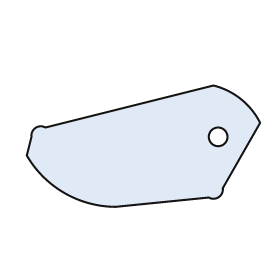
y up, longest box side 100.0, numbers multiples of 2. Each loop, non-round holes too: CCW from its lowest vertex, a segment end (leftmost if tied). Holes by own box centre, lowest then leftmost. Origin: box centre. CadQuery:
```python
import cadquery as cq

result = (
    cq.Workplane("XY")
    .moveTo(-12.0, -26.0)
    .lineTo(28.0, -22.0)
    .threePointArc((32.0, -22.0), (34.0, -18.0))
    .lineTo(50.0, 10.0)
    .threePointArc((42.0, 20.0), (30.0, 26.0))
    .lineTo(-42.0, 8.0)
    .threePointArc((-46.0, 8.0), (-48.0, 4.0))
    .lineTo(-50.0, -4.0)
    .threePointArc((-34.0, -20.0), (-12.0, -26.0))
    .close()
    .moveTo(32.0, 4.0)
    .circle(4.0)
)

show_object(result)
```